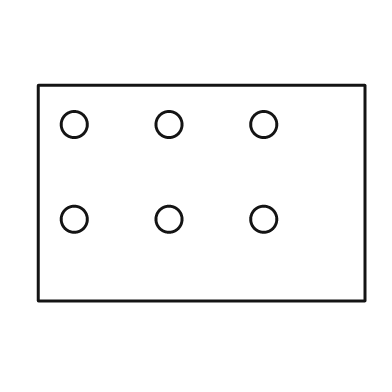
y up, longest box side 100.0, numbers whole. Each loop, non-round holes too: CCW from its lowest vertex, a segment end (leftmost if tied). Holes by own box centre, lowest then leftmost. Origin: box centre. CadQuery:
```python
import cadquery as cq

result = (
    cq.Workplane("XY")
    .moveTo(-50.0, -33.0)
    .lineTo(50.0, -33.0)
    .lineTo(50.0, 33.0)
    .lineTo(-50.0, 33.0)
    .close()
    .moveTo(-39.0, -8.0)
    .circle(4.0)
    .moveTo(-10.0, -8.0)
    .circle(4.0)
    .moveTo(19.0, -8.0)
    .circle(4.0)
    .moveTo(-39.0, 21.0)
    .circle(4.0)
    .moveTo(-10.0, 21.0)
    .circle(4.0)
    .moveTo(19.0, 21.0)
    .circle(4.0)
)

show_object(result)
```